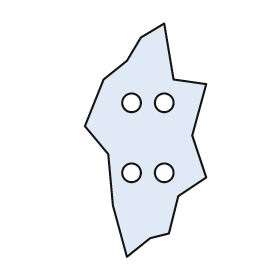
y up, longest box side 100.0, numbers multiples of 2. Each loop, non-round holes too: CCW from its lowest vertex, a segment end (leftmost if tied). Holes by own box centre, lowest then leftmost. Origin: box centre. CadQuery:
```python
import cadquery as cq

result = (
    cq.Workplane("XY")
    .moveTo(-8.0, -50.0)
    .lineTo(2.0, -42.0)
    .lineTo(10.0, -40.0)
    .lineTo(14.0, -24.0)
    .lineTo(26.0, -16.0)
    .lineTo(20.0, 2.0)
    .lineTo(26.0, 24.0)
    .lineTo(12.0, 26.0)
    .lineTo(8.0, 50.0)
    .lineTo(-2.0, 44.0)
    .lineTo(-8.0, 34.0)
    .lineTo(-18.0, 26.0)
    .lineTo(-26.0, 6.0)
    .lineTo(-16.0, -6.0)
    .lineTo(-14.0, -28.0)
    .close()
    .moveTo(-6.0, -14.0)
    .circle(4.0)
    .moveTo(8.0, -14.0)
    .circle(4.0)
    .moveTo(-6.0, 16.0)
    .circle(4.0)
    .moveTo(8.0, 16.0)
    .circle(4.0)
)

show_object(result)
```